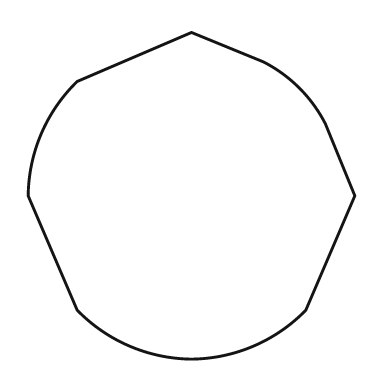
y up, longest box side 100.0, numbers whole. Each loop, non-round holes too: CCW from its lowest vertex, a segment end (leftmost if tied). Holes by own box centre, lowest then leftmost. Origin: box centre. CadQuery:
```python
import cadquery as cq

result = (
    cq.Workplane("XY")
    .moveTo(0.0, -50.0)
    .threePointArc((19.0, -46.0), (35.0, -35.0))
    .lineTo(50.0, 0.0)
    .lineTo(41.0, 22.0)
    .threePointArc((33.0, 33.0), (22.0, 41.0))
    .lineTo(0.0, 50.0)
    .lineTo(-35.0, 35.0)
    .threePointArc((-46.0, 19.0), (-50.0, 0.0))
    .lineTo(-35.0, -35.0)
    .threePointArc((-19.0, -46.0), (0.0, -50.0))
    .close()
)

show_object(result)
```